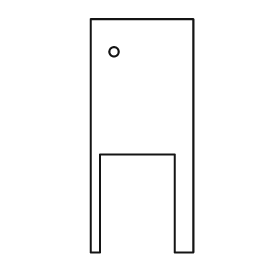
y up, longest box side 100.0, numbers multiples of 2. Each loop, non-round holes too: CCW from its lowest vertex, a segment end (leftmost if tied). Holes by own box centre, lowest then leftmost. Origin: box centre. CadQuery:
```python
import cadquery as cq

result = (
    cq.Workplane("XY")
    .moveTo(-22.0, -50.0)
    .lineTo(-18.0, -50.0)
    .lineTo(-18.0, -8.0)
    .lineTo(14.0, -8.0)
    .lineTo(14.0, -50.0)
    .lineTo(22.0, -50.0)
    .lineTo(22.0, 50.0)
    .lineTo(-22.0, 50.0)
    .close()
    .moveTo(-12.0, 36.0)
    .circle(2.0)
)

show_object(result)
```